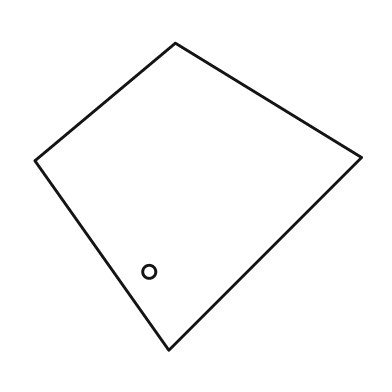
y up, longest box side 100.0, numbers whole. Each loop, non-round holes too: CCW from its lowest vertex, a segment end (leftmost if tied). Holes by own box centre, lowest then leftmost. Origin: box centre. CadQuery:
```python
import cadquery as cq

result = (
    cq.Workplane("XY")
    .moveTo(-9.0, -47.0)
    .lineTo(50.0, 12.0)
    .lineTo(-7.0, 47.0)
    .lineTo(-50.0, 11.0)
    .close()
    .moveTo(-15.0, -23.0)
    .circle(2.0)
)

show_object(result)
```